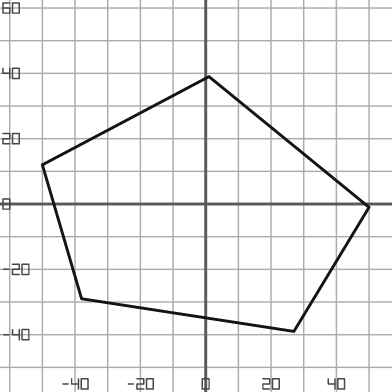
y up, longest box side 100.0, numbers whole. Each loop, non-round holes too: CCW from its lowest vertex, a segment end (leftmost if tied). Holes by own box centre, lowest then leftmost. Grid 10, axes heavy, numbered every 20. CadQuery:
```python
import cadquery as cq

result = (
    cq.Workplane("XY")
    .moveTo(27.0, -39.0)
    .lineTo(50.0, -1.0)
    .lineTo(1.0, 39.0)
    .lineTo(-50.0, 12.0)
    .lineTo(-38.0, -29.0)
    .close()
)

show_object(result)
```